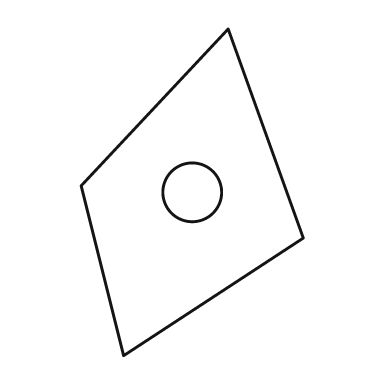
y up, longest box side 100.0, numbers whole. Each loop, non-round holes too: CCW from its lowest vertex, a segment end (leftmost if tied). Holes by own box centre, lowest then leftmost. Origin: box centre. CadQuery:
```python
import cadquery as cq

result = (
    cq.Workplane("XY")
    .moveTo(-21.0, -50.0)
    .lineTo(34.0, -14.0)
    .lineTo(11.0, 50.0)
    .lineTo(-34.0, 2.0)
    .close()
    .moveTo(0.0, 0.0)
    .circle(9.0)
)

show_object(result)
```